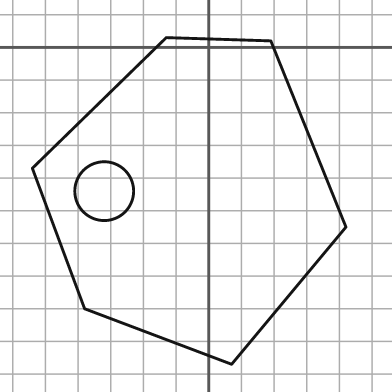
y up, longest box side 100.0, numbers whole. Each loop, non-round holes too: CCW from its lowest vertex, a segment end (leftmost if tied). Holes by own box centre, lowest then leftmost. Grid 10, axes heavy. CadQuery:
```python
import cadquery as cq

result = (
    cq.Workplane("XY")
    .moveTo(7.0, -97.0)
    .lineTo(42.0, -55.0)
    .lineTo(19.0, 2.0)
    .lineTo(-13.0, 3.0)
    .lineTo(-54.0, -37.0)
    .lineTo(-38.0, -80.0)
    .close()
    .moveTo(-32.0, -44.0)
    .circle(9.0)
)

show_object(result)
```